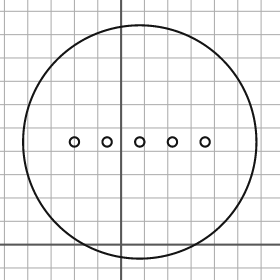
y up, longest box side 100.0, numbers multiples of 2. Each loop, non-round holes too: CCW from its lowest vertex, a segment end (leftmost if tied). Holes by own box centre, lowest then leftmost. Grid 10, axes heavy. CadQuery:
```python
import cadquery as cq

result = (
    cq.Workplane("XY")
    .moveTo(8.0, 44.0)
    .circle(50.0)
    .moveTo(-20.0, 44.0)
    .circle(2.0)
    .moveTo(-6.0, 44.0)
    .circle(2.0)
    .moveTo(8.0, 44.0)
    .circle(2.0)
    .moveTo(22.0, 44.0)
    .circle(2.0)
    .moveTo(36.0, 44.0)
    .circle(2.0)
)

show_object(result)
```